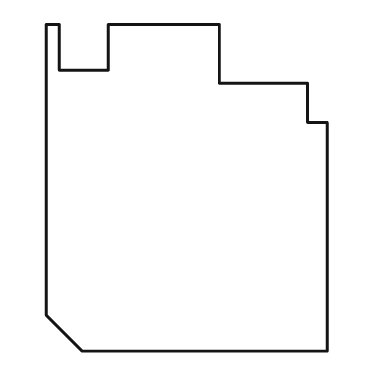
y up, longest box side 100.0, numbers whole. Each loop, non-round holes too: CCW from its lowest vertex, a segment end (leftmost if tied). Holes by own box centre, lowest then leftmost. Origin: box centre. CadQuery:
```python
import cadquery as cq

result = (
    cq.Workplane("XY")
    .moveTo(-32.0, -50.0)
    .lineTo(43.0, -50.0)
    .lineTo(43.0, 20.0)
    .lineTo(37.0, 20.0)
    .lineTo(37.0, 32.0)
    .lineTo(10.0, 32.0)
    .lineTo(10.0, 50.0)
    .lineTo(-24.0, 50.0)
    .lineTo(-24.0, 36.0)
    .lineTo(-39.0, 36.0)
    .lineTo(-39.0, 50.0)
    .lineTo(-43.0, 50.0)
    .lineTo(-43.0, -39.0)
    .close()
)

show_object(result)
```